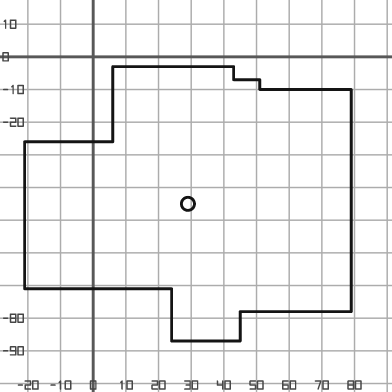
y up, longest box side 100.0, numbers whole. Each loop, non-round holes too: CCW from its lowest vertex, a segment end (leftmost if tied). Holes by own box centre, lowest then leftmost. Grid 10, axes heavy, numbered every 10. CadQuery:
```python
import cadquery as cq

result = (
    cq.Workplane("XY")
    .moveTo(24.0, -87.0)
    .lineTo(45.0, -87.0)
    .lineTo(45.0, -78.0)
    .lineTo(79.0, -78.0)
    .lineTo(79.0, -10.0)
    .lineTo(51.0, -10.0)
    .lineTo(51.0, -7.0)
    .lineTo(43.0, -7.0)
    .lineTo(43.0, -3.0)
    .lineTo(6.0, -3.0)
    .lineTo(6.0, -26.0)
    .lineTo(-21.0, -26.0)
    .lineTo(-21.0, -71.0)
    .lineTo(24.0, -71.0)
    .close()
    .moveTo(29.0, -45.0)
    .circle(2.0)
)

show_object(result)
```